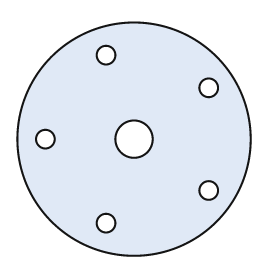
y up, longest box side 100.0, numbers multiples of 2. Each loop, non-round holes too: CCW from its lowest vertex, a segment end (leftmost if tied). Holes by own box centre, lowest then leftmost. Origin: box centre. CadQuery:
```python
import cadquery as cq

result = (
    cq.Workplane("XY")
    .moveTo(0.0, 0.0)
    .circle(50.0)
    .moveTo(-12.0, -36.0)
    .circle(4.0)
    .moveTo(32.0, -22.0)
    .circle(4.0)
    .moveTo(-38.0, 0.0)
    .circle(4.0)
    .moveTo(0.0, 0.0)
    .circle(8.0)
    .moveTo(32.0, 22.0)
    .circle(4.0)
    .moveTo(-12.0, 36.0)
    .circle(4.0)
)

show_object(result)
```